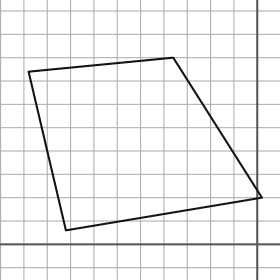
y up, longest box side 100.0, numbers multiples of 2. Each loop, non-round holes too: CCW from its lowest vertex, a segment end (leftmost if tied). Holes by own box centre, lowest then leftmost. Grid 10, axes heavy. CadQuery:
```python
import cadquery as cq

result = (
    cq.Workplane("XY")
    .moveTo(-82.0, 6.0)
    .lineTo(2.0, 20.0)
    .lineTo(-36.0, 80.0)
    .lineTo(-98.0, 74.0)
    .close()
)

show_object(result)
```